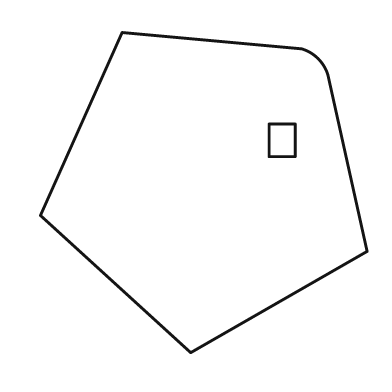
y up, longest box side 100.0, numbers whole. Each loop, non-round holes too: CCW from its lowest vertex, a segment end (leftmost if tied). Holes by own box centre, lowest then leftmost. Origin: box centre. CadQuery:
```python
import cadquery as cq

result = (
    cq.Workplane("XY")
    .moveTo(-4.0, -49.0)
    .lineTo(50.0, -18.0)
    .lineTo(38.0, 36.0)
    .threePointArc((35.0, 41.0), (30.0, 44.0))
    .lineTo(-25.0, 49.0)
    .lineTo(-50.0, -7.0)
    .close()
    .moveTo(20.0, 11.0)
    .lineTo(28.0, 11.0)
    .lineTo(28.0, 21.0)
    .lineTo(20.0, 21.0)
    .close()
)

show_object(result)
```